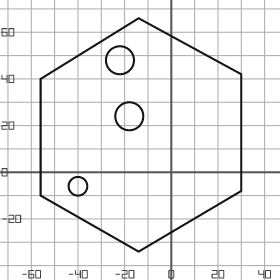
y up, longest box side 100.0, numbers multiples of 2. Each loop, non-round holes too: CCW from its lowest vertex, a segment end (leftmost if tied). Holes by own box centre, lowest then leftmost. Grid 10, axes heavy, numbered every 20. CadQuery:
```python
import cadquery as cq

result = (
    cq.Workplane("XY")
    .moveTo(-14.0, -34.0)
    .lineTo(30.0, -8.0)
    .lineTo(30.0, 42.0)
    .lineTo(-14.0, 66.0)
    .lineTo(-56.0, 40.0)
    .lineTo(-56.0, -10.0)
    .close()
    .moveTo(-40.0, -6.0)
    .circle(4.0)
    .moveTo(-18.0, 24.0)
    .circle(6.0)
    .moveTo(-22.0, 48.0)
    .circle(6.0)
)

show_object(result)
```